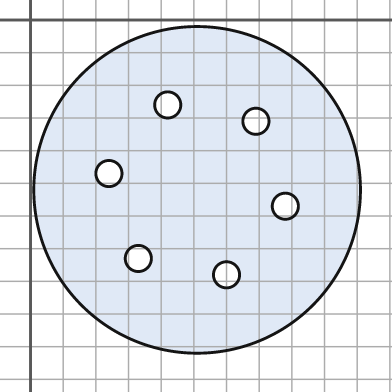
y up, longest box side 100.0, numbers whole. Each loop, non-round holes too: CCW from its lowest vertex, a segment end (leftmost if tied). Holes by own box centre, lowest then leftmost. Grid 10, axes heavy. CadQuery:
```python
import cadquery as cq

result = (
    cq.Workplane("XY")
    .moveTo(51.0, -52.0)
    .circle(50.0)
    .moveTo(60.0, -78.0)
    .circle(4.0)
    .moveTo(33.0, -73.0)
    .circle(4.0)
    .moveTo(78.0, -57.0)
    .circle(4.0)
    .moveTo(24.0, -47.0)
    .circle(4.0)
    .moveTo(69.0, -31.0)
    .circle(4.0)
    .moveTo(42.0, -26.0)
    .circle(4.0)
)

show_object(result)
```